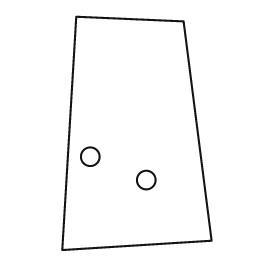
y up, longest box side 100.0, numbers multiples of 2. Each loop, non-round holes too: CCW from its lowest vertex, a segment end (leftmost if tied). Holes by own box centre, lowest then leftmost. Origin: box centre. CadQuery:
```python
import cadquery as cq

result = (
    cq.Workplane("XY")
    .moveTo(-32.0, -50.0)
    .lineTo(32.0, -46.0)
    .lineTo(20.0, 48.0)
    .lineTo(-26.0, 50.0)
    .close()
    .moveTo(4.0, -20.0)
    .circle(4.0)
    .moveTo(-20.0, -10.0)
    .circle(4.0)
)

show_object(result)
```